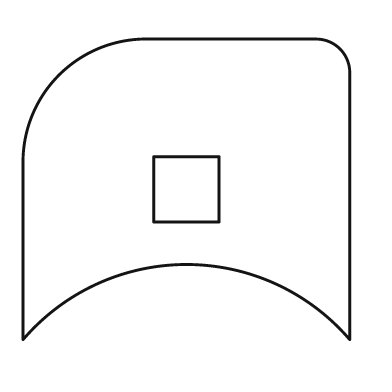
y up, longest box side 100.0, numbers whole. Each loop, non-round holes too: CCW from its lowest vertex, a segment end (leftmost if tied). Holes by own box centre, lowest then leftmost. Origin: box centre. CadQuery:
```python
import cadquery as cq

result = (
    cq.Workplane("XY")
    .moveTo(-50.0, -46.0)
    .threePointArc((0.0, -23.0), (50.0, -46.0))
    .lineTo(50.0, 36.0)
    .threePointArc((47.0, 43.0), (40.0, 46.0))
    .lineTo(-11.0, 46.0)
    .threePointArc((-39.0, 35.0), (-50.0, 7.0))
    .close()
    .moveTo(-10.0, -10.0)
    .lineTo(10.0, -10.0)
    .lineTo(10.0, 10.0)
    .lineTo(-10.0, 10.0)
    .close()
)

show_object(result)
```